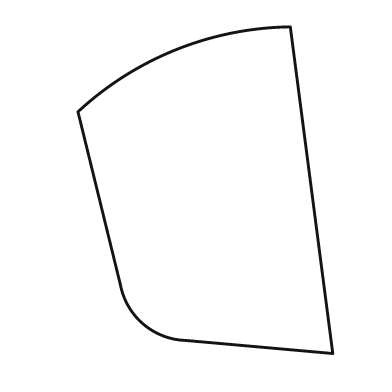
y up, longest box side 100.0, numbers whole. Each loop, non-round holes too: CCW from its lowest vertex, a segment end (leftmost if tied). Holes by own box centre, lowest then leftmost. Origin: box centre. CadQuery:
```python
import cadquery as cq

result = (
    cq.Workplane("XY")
    .moveTo(39.0, -50.0)
    .lineTo(26.0, 50.0)
    .threePointArc((-9.0, 43.0), (-39.0, 24.0))
    .lineTo(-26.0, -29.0)
    .threePointArc((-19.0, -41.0), (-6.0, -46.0))
    .close()
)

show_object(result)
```